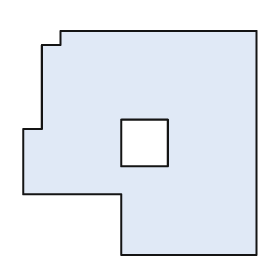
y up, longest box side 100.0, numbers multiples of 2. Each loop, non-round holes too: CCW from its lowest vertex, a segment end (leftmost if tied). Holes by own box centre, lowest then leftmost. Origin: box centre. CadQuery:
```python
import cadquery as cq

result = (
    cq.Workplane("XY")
    .moveTo(-8.0, -48.0)
    .lineTo(50.0, -48.0)
    .lineTo(50.0, 48.0)
    .lineTo(-34.0, 48.0)
    .lineTo(-34.0, 42.0)
    .lineTo(-42.0, 42.0)
    .lineTo(-42.0, 6.0)
    .lineTo(-50.0, 6.0)
    .lineTo(-50.0, -22.0)
    .lineTo(-8.0, -22.0)
    .close()
    .moveTo(-8.0, -10.0)
    .lineTo(12.0, -10.0)
    .lineTo(12.0, 10.0)
    .lineTo(-8.0, 10.0)
    .close()
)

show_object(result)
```